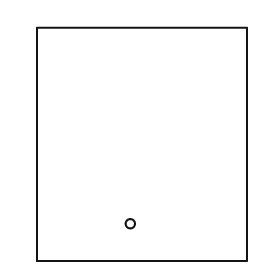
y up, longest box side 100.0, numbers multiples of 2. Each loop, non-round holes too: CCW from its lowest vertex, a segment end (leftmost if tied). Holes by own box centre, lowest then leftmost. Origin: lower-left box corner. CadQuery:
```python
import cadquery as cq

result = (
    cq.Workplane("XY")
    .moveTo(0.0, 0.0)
    .lineTo(90.0, 0.0)
    .lineTo(90.0, 100.0)
    .lineTo(0.0, 100.0)
    .close()
    .moveTo(40.0, 16.0)
    .circle(2.0)
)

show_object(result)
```